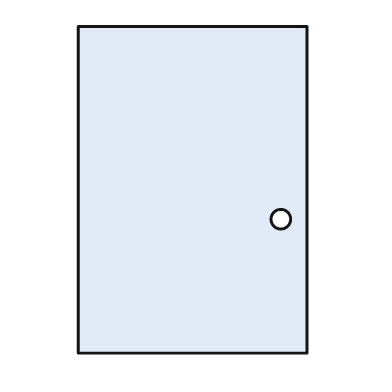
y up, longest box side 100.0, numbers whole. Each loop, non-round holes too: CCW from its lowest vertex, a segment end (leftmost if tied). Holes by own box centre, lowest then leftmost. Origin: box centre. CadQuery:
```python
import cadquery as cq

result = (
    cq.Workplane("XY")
    .moveTo(-35.0, -50.0)
    .lineTo(35.0, -50.0)
    .lineTo(35.0, 50.0)
    .lineTo(-35.0, 50.0)
    .close()
    .moveTo(27.0, -9.0)
    .circle(3.0)
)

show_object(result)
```